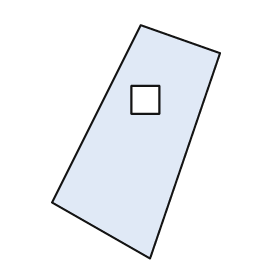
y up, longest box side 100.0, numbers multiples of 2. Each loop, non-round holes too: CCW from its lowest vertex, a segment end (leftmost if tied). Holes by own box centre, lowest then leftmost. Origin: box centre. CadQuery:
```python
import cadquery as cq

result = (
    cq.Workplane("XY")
    .moveTo(6.0, -50.0)
    .lineTo(36.0, 38.0)
    .lineTo(2.0, 50.0)
    .lineTo(-36.0, -26.0)
    .close()
    .moveTo(-2.0, 12.0)
    .lineTo(10.0, 12.0)
    .lineTo(10.0, 24.0)
    .lineTo(-2.0, 24.0)
    .close()
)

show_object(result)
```